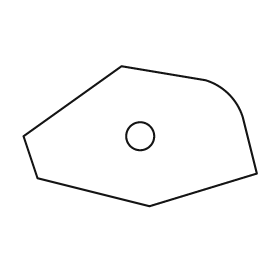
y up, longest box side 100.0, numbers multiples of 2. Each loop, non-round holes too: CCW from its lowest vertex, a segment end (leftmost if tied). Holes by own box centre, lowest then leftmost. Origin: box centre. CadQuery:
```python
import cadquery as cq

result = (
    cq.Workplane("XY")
    .moveTo(4.0, -30.0)
    .lineTo(50.0, -16.0)
    .lineTo(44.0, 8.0)
    .threePointArc((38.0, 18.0), (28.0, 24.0))
    .lineTo(-8.0, 30.0)
    .lineTo(-50.0, 0.0)
    .lineTo(-44.0, -18.0)
    .close()
    .moveTo(0.0, 0.0)
    .circle(6.0)
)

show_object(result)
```